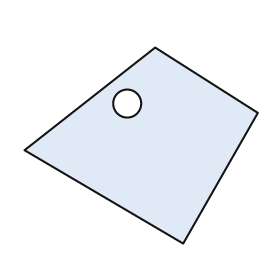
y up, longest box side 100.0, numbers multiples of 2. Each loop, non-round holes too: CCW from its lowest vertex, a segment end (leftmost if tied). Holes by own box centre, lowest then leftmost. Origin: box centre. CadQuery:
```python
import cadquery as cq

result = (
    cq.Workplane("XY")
    .moveTo(18.0, -42.0)
    .lineTo(50.0, 14.0)
    .lineTo(6.0, 42.0)
    .lineTo(-50.0, -2.0)
    .close()
    .moveTo(-6.0, 18.0)
    .circle(6.0)
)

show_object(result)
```